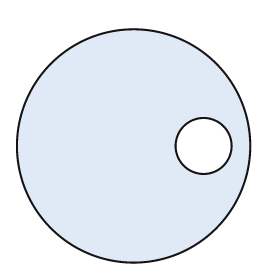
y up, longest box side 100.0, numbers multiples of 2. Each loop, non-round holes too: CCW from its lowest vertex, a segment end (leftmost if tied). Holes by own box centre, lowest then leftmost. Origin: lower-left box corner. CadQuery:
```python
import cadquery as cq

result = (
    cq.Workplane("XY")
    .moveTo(50.0, 50.0)
    .circle(50.0)
    .moveTo(80.0, 50.0)
    .circle(12.0)
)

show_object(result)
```